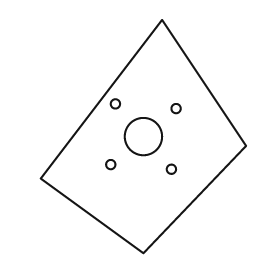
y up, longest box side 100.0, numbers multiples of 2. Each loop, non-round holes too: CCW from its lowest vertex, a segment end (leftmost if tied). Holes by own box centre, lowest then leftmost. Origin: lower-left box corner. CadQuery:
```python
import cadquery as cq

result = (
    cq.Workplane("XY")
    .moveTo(44.0, 0.0)
    .lineTo(88.0, 46.0)
    .lineTo(52.0, 100.0)
    .lineTo(0.0, 32.0)
    .close()
    .moveTo(56.0, 36.0)
    .circle(2.0)
    .moveTo(30.0, 38.0)
    .circle(2.0)
    .moveTo(44.0, 50.0)
    .circle(8.0)
    .moveTo(58.0, 62.0)
    .circle(2.0)
    .moveTo(32.0, 64.0)
    .circle(2.0)
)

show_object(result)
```